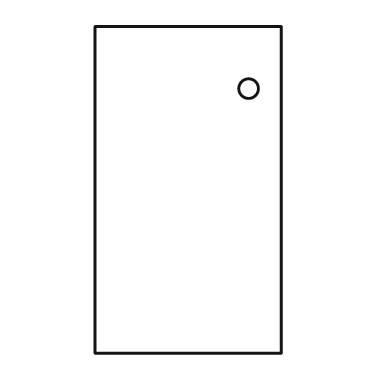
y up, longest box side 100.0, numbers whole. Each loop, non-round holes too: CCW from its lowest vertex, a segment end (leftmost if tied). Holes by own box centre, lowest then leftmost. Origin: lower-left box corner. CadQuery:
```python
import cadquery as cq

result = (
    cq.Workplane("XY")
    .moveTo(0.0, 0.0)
    .lineTo(57.0, 0.0)
    .lineTo(57.0, 100.0)
    .lineTo(0.0, 100.0)
    .close()
    .moveTo(47.0, 81.0)
    .circle(3.0)
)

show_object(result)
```